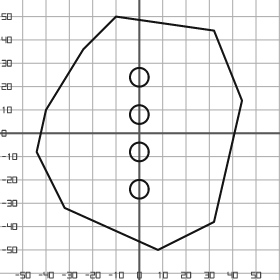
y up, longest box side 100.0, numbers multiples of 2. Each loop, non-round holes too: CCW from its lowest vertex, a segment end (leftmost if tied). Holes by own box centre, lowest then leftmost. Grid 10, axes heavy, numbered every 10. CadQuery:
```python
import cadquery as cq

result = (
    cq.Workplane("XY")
    .moveTo(8.0, -50.0)
    .lineTo(32.0, -38.0)
    .lineTo(44.0, 14.0)
    .lineTo(32.0, 44.0)
    .lineTo(-10.0, 50.0)
    .lineTo(-24.0, 36.0)
    .lineTo(-40.0, 10.0)
    .lineTo(-44.0, -8.0)
    .lineTo(-32.0, -32.0)
    .close()
    .moveTo(0.0, -24.0)
    .circle(4.0)
    .moveTo(0.0, -8.0)
    .circle(4.0)
    .moveTo(0.0, 8.0)
    .circle(4.0)
    .moveTo(0.0, 24.0)
    .circle(4.0)
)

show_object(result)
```